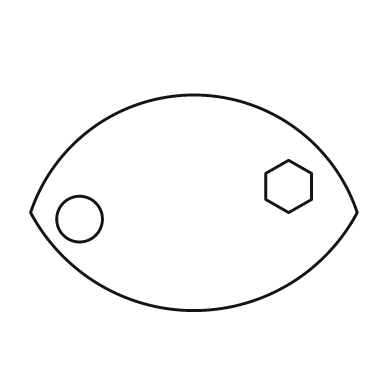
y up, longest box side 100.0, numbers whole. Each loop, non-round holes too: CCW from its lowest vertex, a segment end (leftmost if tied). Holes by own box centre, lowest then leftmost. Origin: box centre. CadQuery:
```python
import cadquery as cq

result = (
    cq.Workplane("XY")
    .moveTo(-50.0, -3.0)
    .threePointArc((0.0, -33.0), (50.0, -3.0))
    .threePointArc((0.0, 33.0), (-50.0, -3.0))
    .close()
    .moveTo(-35.0, -5.0)
    .circle(7.0)
    .moveTo(29.0, -3.0)
    .lineTo(36.0, 1.0)
    .lineTo(36.0, 9.0)
    .lineTo(29.0, 13.0)
    .lineTo(22.0, 9.0)
    .lineTo(22.0, 1.0)
    .close()
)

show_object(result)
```